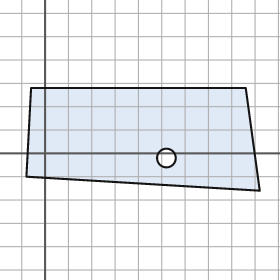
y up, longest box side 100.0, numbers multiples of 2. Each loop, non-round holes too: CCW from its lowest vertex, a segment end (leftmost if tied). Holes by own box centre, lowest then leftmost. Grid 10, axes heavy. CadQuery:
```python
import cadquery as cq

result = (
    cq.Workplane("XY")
    .moveTo(92.0, -16.0)
    .lineTo(86.0, 28.0)
    .lineTo(-6.0, 28.0)
    .lineTo(-8.0, -10.0)
    .close()
    .moveTo(52.0, -2.0)
    .circle(4.0)
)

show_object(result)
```